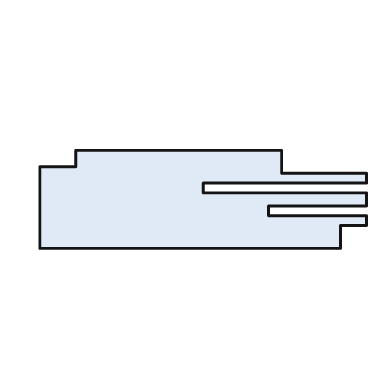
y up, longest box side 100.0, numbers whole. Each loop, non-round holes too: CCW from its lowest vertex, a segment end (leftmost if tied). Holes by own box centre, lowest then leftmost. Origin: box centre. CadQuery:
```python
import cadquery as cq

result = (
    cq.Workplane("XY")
    .moveTo(-50.0, -15.0)
    .lineTo(42.0, -15.0)
    .lineTo(42.0, -8.0)
    .lineTo(50.0, -8.0)
    .lineTo(50.0, -5.0)
    .lineTo(20.0, -5.0)
    .lineTo(20.0, -2.0)
    .lineTo(50.0, -2.0)
    .lineTo(50.0, 2.0)
    .lineTo(0.0, 2.0)
    .lineTo(0.0, 5.0)
    .lineTo(50.0, 5.0)
    .lineTo(50.0, 8.0)
    .lineTo(24.0, 8.0)
    .lineTo(24.0, 15.0)
    .lineTo(-39.0, 15.0)
    .lineTo(-39.0, 10.0)
    .lineTo(-50.0, 10.0)
    .close()
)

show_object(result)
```